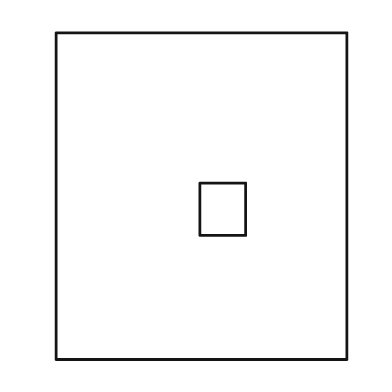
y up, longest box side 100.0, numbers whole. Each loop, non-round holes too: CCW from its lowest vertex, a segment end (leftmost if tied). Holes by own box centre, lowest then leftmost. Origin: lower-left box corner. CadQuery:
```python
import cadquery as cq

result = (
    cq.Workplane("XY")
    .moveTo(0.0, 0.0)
    .lineTo(89.0, 0.0)
    .lineTo(89.0, 100.0)
    .lineTo(0.0, 100.0)
    .close()
    .moveTo(44.0, 38.0)
    .lineTo(58.0, 38.0)
    .lineTo(58.0, 54.0)
    .lineTo(44.0, 54.0)
    .close()
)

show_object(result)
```